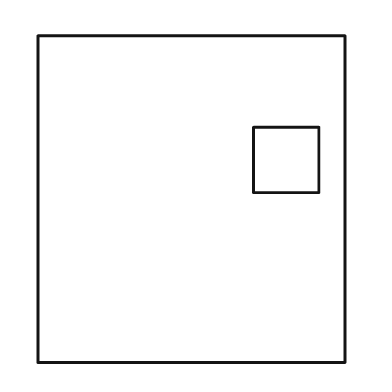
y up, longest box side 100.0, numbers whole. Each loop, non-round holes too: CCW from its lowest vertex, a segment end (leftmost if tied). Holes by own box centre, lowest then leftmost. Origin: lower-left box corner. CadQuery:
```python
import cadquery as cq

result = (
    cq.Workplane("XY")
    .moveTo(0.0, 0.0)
    .lineTo(94.0, 0.0)
    .lineTo(94.0, 100.0)
    .lineTo(0.0, 100.0)
    .close()
    .moveTo(66.0, 52.0)
    .lineTo(86.0, 52.0)
    .lineTo(86.0, 72.0)
    .lineTo(66.0, 72.0)
    .close()
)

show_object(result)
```